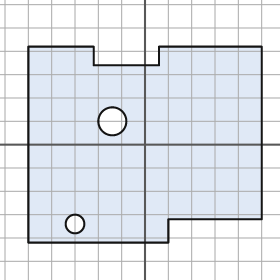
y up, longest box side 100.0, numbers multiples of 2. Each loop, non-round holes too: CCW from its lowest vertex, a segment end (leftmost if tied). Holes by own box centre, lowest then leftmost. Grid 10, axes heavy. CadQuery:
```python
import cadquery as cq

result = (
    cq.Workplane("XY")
    .moveTo(-50.0, -42.0)
    .lineTo(10.0, -42.0)
    .lineTo(10.0, -32.0)
    .lineTo(50.0, -32.0)
    .lineTo(50.0, 42.0)
    .lineTo(6.0, 42.0)
    .lineTo(6.0, 34.0)
    .lineTo(-22.0, 34.0)
    .lineTo(-22.0, 42.0)
    .lineTo(-50.0, 42.0)
    .close()
    .moveTo(-30.0, -34.0)
    .circle(4.0)
    .moveTo(-14.0, 10.0)
    .circle(6.0)
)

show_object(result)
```